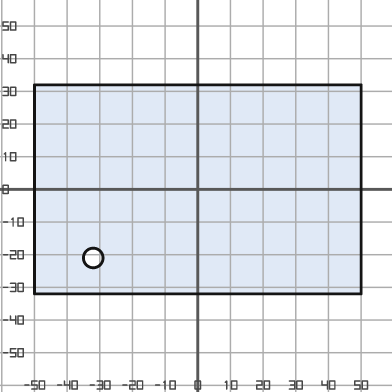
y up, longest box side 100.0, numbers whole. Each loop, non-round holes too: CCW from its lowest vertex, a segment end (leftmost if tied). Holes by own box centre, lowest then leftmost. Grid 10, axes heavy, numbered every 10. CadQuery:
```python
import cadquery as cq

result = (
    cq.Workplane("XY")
    .moveTo(-50.0, -32.0)
    .lineTo(50.0, -32.0)
    .lineTo(50.0, 32.0)
    .lineTo(-50.0, 32.0)
    .close()
    .moveTo(-32.0, -21.0)
    .circle(3.0)
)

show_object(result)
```